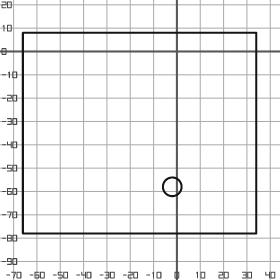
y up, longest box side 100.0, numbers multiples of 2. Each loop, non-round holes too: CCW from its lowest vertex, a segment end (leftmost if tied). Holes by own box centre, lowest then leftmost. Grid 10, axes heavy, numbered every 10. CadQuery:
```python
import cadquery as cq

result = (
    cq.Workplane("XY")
    .moveTo(-66.0, -78.0)
    .lineTo(34.0, -78.0)
    .lineTo(34.0, 8.0)
    .lineTo(-66.0, 8.0)
    .close()
    .moveTo(-2.0, -58.0)
    .circle(4.0)
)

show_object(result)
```